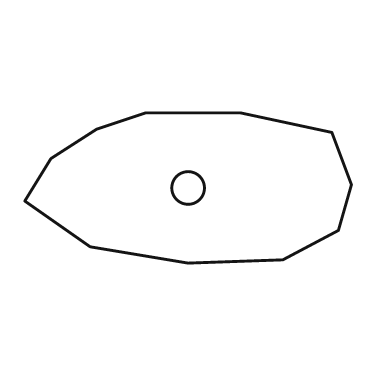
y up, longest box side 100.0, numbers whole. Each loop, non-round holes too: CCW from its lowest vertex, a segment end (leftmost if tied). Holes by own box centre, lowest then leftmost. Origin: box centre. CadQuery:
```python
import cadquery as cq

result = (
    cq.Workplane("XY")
    .moveTo(0.0, -23.0)
    .lineTo(29.0, -22.0)
    .lineTo(46.0, -13.0)
    .lineTo(50.0, 1.0)
    .lineTo(44.0, 17.0)
    .lineTo(16.0, 23.0)
    .lineTo(-13.0, 23.0)
    .lineTo(-28.0, 18.0)
    .lineTo(-42.0, 9.0)
    .lineTo(-50.0, -4.0)
    .lineTo(-30.0, -18.0)
    .close()
    .moveTo(0.0, 0.0)
    .circle(5.0)
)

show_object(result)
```